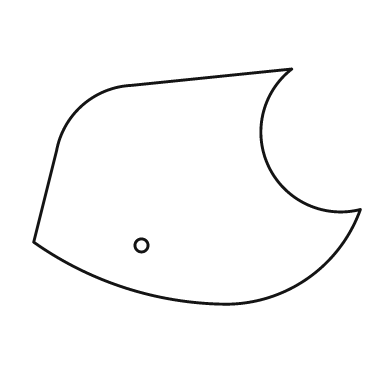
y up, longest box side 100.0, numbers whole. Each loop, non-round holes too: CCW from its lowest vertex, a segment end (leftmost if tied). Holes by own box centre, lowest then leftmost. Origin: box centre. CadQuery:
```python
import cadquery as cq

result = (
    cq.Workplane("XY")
    .moveTo(9.0, -36.0)
    .threePointArc((34.0, -28.0), (50.0, -7.0))
    .threePointArc((22.0, 6.0), (29.0, 36.0))
    .lineTo(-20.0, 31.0)
    .threePointArc((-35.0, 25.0), (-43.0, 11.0))
    .lineTo(-50.0, -17.0)
    .threePointArc((-22.0, -31.0), (9.0, -36.0))
    .close()
    .moveTo(-17.0, -18.0)
    .circle(2.0)
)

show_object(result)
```